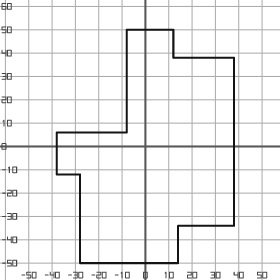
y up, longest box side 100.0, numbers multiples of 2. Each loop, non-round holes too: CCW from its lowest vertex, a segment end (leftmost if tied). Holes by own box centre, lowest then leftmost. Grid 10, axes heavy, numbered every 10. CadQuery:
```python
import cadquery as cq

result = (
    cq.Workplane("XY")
    .moveTo(-28.0, -50.0)
    .lineTo(14.0, -50.0)
    .lineTo(14.0, -34.0)
    .lineTo(38.0, -34.0)
    .lineTo(38.0, 38.0)
    .lineTo(12.0, 38.0)
    .lineTo(12.0, 50.0)
    .lineTo(-8.0, 50.0)
    .lineTo(-8.0, 6.0)
    .lineTo(-38.0, 6.0)
    .lineTo(-38.0, -12.0)
    .lineTo(-28.0, -12.0)
    .close()
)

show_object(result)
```